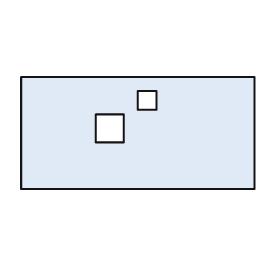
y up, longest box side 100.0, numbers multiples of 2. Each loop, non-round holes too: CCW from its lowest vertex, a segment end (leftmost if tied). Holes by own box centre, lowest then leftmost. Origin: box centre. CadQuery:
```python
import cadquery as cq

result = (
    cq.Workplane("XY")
    .moveTo(-50.0, -24.0)
    .lineTo(50.0, -24.0)
    .lineTo(50.0, 24.0)
    .lineTo(-50.0, 24.0)
    .close()
    .moveTo(-18.0, -4.0)
    .lineTo(-6.0, -4.0)
    .lineTo(-6.0, 8.0)
    .lineTo(-18.0, 8.0)
    .close()
    .moveTo(0.0, 10.0)
    .lineTo(8.0, 10.0)
    .lineTo(8.0, 18.0)
    .lineTo(0.0, 18.0)
    .close()
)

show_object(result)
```